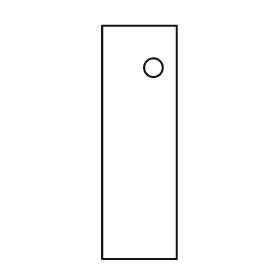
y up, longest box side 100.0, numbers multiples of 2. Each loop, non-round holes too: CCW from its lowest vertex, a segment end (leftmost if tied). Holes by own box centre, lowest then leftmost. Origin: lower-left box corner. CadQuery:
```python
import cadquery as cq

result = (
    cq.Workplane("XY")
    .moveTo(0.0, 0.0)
    .lineTo(32.0, 0.0)
    .lineTo(32.0, 100.0)
    .lineTo(0.0, 100.0)
    .close()
    .moveTo(22.0, 82.0)
    .circle(4.0)
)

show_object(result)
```